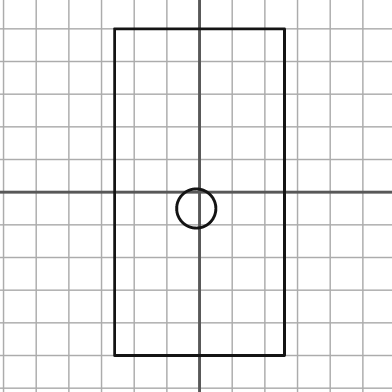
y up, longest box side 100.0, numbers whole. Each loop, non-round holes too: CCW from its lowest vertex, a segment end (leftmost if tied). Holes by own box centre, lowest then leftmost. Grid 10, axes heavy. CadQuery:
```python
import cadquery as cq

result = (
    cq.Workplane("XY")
    .moveTo(-26.0, -50.0)
    .lineTo(26.0, -50.0)
    .lineTo(26.0, 50.0)
    .lineTo(-26.0, 50.0)
    .close()
    .moveTo(-1.0, -5.0)
    .circle(6.0)
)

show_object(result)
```